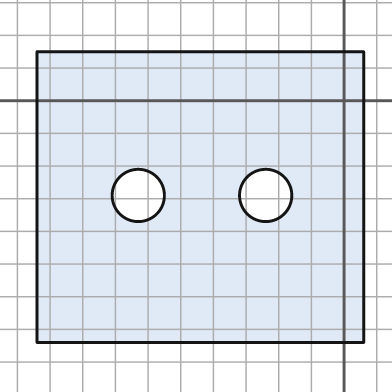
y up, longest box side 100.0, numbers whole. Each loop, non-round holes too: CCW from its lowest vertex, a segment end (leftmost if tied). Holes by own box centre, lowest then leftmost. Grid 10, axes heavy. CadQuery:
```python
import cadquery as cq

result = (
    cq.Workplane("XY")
    .moveTo(-94.0, -74.0)
    .lineTo(6.0, -74.0)
    .lineTo(6.0, 15.0)
    .lineTo(-94.0, 15.0)
    .close()
    .moveTo(-63.0, -29.0)
    .circle(8.0)
    .moveTo(-24.0, -29.0)
    .circle(8.0)
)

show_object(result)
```